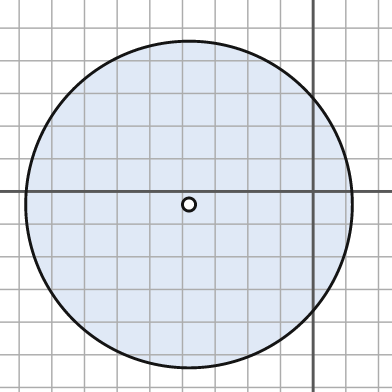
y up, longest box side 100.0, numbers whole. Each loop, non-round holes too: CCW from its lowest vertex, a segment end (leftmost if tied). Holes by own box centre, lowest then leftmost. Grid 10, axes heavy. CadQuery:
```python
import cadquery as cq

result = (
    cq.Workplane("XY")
    .moveTo(-38.0, -4.0)
    .circle(50.0)
    .moveTo(-38.0, -4.0)
    .circle(2.0)
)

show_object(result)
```